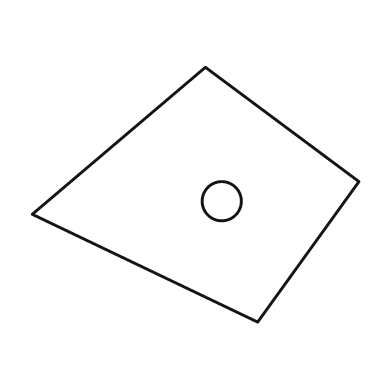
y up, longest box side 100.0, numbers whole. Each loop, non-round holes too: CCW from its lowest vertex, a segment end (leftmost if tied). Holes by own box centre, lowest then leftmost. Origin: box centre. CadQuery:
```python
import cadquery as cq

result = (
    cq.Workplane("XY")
    .moveTo(19.0, -39.0)
    .lineTo(50.0, 4.0)
    .lineTo(3.0, 39.0)
    .lineTo(-50.0, -6.0)
    .close()
    .moveTo(8.0, -2.0)
    .circle(6.0)
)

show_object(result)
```